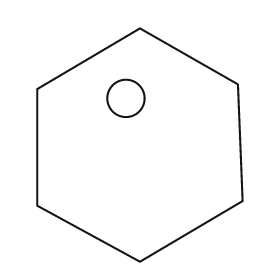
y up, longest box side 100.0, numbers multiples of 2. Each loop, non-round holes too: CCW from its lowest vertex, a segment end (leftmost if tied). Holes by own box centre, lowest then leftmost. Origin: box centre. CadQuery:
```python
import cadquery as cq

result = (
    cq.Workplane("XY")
    .moveTo(0.0, -50.0)
    .lineTo(44.0, -24.0)
    .lineTo(42.0, 26.0)
    .lineTo(0.0, 50.0)
    .lineTo(-44.0, 24.0)
    .lineTo(-44.0, -26.0)
    .close()
    .moveTo(-6.0, 20.0)
    .circle(8.0)
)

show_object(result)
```